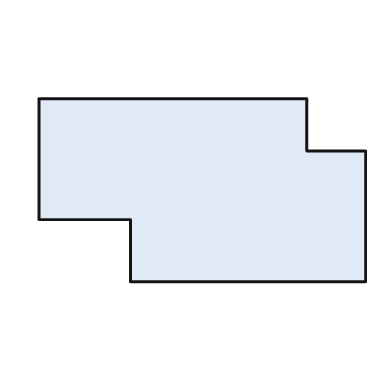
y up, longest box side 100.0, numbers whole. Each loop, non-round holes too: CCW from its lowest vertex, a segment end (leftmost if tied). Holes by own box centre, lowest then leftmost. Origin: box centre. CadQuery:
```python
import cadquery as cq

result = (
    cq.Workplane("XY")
    .moveTo(-22.0, -28.0)
    .lineTo(50.0, -28.0)
    .lineTo(50.0, 12.0)
    .lineTo(32.0, 12.0)
    .lineTo(32.0, 28.0)
    .lineTo(-50.0, 28.0)
    .lineTo(-50.0, -9.0)
    .lineTo(-22.0, -9.0)
    .close()
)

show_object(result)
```